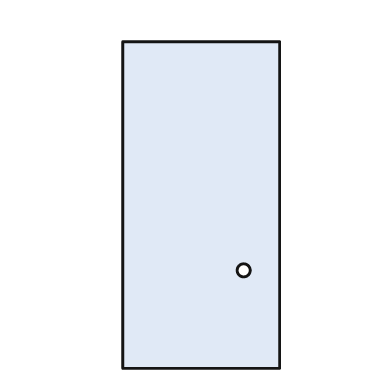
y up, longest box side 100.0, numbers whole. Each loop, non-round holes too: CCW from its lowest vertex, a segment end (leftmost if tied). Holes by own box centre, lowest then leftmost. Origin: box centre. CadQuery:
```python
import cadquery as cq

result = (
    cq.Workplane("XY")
    .moveTo(-24.0, -50.0)
    .lineTo(24.0, -50.0)
    .lineTo(24.0, 50.0)
    .lineTo(-24.0, 50.0)
    .close()
    .moveTo(13.0, -20.0)
    .circle(2.0)
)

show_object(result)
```